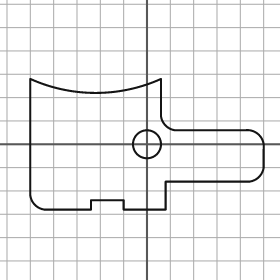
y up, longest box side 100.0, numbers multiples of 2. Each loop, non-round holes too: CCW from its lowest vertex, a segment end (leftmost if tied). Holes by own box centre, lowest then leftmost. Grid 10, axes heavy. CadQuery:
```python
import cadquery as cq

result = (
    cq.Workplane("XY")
    .moveTo(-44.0, -28.0)
    .lineTo(-24.0, -28.0)
    .lineTo(-24.0, -24.0)
    .lineTo(-10.0, -24.0)
    .lineTo(-10.0, -28.0)
    .lineTo(8.0, -28.0)
    .lineTo(8.0, -16.0)
    .lineTo(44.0, -16.0)
    .threePointArc((48.0, -14.0), (50.0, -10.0))
    .lineTo(50.0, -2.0)
    .threePointArc((48.0, 4.0), (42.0, 6.0))
    .lineTo(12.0, 6.0)
    .threePointArc((8.0, 8.0), (6.0, 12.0))
    .lineTo(6.0, 28.0)
    .threePointArc((-22.0, 22.0), (-50.0, 28.0))
    .lineTo(-50.0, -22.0)
    .threePointArc((-48.0, -26.0), (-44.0, -28.0))
    .close()
    .moveTo(0.0, 0.0)
    .circle(6.0)
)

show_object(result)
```